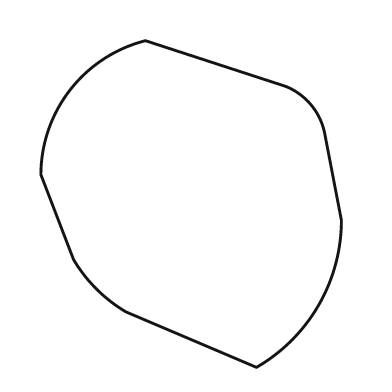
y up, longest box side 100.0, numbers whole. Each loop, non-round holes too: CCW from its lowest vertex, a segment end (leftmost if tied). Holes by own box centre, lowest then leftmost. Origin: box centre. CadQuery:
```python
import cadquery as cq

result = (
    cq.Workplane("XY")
    .moveTo(20.0, -50.0)
    .threePointArc((39.0, -31.0), (46.0, -5.0))
    .lineTo(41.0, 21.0)
    .threePointArc((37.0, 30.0), (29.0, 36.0))
    .lineTo(-14.0, 50.0)
    .threePointArc((-37.0, 35.0), (-46.0, 9.0))
    .lineTo(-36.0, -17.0)
    .threePointArc((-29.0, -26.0), (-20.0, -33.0))
    .close()
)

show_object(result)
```